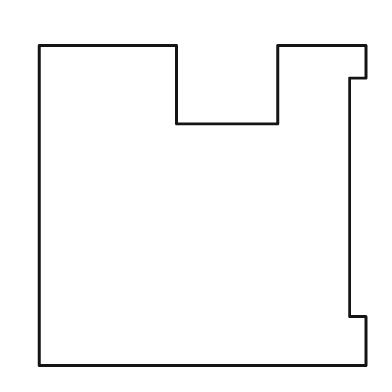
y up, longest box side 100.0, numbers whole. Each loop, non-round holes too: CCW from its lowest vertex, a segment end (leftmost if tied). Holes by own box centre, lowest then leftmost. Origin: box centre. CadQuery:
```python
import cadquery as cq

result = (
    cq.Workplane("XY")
    .moveTo(-50.0, -49.0)
    .lineTo(50.0, -49.0)
    .lineTo(50.0, -34.0)
    .lineTo(45.0, -34.0)
    .lineTo(45.0, 39.0)
    .lineTo(50.0, 39.0)
    .lineTo(50.0, 49.0)
    .lineTo(23.0, 49.0)
    .lineTo(23.0, 25.0)
    .lineTo(-8.0, 25.0)
    .lineTo(-8.0, 49.0)
    .lineTo(-50.0, 49.0)
    .close()
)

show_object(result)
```